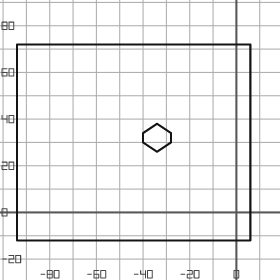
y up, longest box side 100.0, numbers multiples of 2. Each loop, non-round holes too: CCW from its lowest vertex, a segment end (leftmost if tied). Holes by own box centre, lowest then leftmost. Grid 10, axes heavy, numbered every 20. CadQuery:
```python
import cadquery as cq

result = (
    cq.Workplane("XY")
    .moveTo(-94.0, -12.0)
    .lineTo(6.0, -12.0)
    .lineTo(6.0, 72.0)
    .lineTo(-94.0, 72.0)
    .close()
    .moveTo(-34.0, 26.0)
    .lineTo(-28.0, 30.0)
    .lineTo(-28.0, 34.0)
    .lineTo(-34.0, 38.0)
    .lineTo(-40.0, 34.0)
    .lineTo(-40.0, 30.0)
    .close()
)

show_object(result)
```